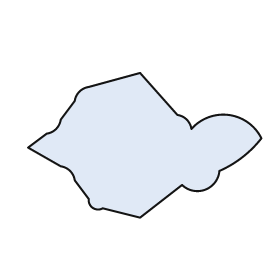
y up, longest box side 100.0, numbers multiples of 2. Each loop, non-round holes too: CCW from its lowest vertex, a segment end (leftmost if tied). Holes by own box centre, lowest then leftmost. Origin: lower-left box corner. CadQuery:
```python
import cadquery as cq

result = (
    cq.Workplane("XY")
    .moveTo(48.0, 0.0)
    .lineTo(66.0, 14.0)
    .threePointArc((76.0, 12.0), (82.0, 20.0))
    .threePointArc((92.0, 26.0), (100.0, 34.0))
    .threePointArc((86.0, 44.0), (70.0, 38.0))
    .threePointArc((68.0, 42.0), (64.0, 44.0))
    .lineTo(48.0, 62.0)
    .lineTo(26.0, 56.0)
    .threePointArc((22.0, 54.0), (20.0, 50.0))
    .lineTo(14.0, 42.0)
    .threePointArc((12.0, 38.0), (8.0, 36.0))
    .lineTo(0.0, 30.0)
    .lineTo(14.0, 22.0)
    .threePointArc((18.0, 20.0), (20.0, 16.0))
    .lineTo(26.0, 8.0)
    .threePointArc((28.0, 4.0), (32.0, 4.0))
    .close()
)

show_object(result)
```